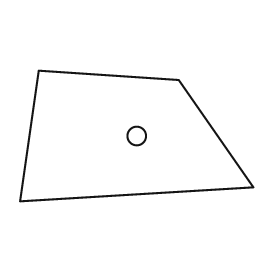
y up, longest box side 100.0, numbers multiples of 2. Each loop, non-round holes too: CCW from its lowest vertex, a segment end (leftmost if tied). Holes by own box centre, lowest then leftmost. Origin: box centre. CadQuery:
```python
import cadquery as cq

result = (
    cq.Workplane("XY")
    .moveTo(-50.0, -28.0)
    .lineTo(50.0, -22.0)
    .lineTo(18.0, 24.0)
    .lineTo(-42.0, 28.0)
    .close()
    .moveTo(0.0, 0.0)
    .circle(4.0)
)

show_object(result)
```